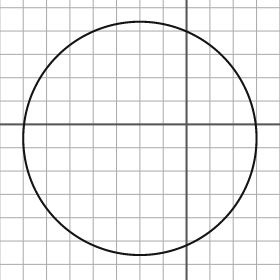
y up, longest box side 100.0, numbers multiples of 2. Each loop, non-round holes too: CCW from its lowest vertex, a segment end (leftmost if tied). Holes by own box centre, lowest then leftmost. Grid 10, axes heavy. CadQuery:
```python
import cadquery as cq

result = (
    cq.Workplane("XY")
    .moveTo(-20.0, -6.0)
    .circle(50.0)
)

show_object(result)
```